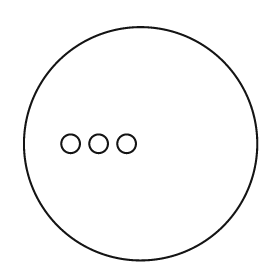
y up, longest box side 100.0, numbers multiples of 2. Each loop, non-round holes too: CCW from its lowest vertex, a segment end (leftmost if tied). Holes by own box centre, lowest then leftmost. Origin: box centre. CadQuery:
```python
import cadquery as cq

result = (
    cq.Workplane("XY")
    .moveTo(0.0, 0.0)
    .circle(50.0)
    .moveTo(-30.0, 0.0)
    .circle(4.0)
    .moveTo(-18.0, 0.0)
    .circle(4.0)
    .moveTo(-6.0, 0.0)
    .circle(4.0)
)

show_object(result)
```